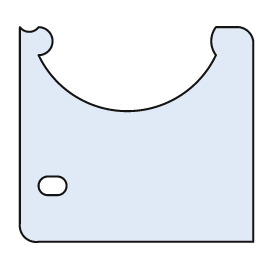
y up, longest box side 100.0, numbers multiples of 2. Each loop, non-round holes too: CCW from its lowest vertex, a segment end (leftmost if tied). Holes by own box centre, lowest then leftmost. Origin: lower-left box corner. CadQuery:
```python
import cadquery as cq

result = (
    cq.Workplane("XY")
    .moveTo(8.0, 0.0)
    .lineTo(100.0, 0.0)
    .lineTo(100.0, 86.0)
    .threePointArc((98.0, 90.0), (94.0, 92.0))
    .lineTo(84.0, 92.0)
    .threePointArc((82.0, 86.0), (84.0, 80.0))
    .threePointArc((46.0, 56.0), (8.0, 80.0))
    .threePointArc((14.0, 86.0), (8.0, 92.0))
    .threePointArc((4.0, 90.0), (0.0, 92.0))
    .lineTo(0.0, 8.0)
    .threePointArc((2.0, 2.0), (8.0, 0.0))
    .close()
    .moveTo(12.0, 20.0)
    .lineTo(16.0, 20.0)
    .threePointArc((20.0, 24.0), (16.0, 28.0))
    .lineTo(12.0, 28.0)
    .threePointArc((8.0, 24.0), (12.0, 20.0))
    .close()
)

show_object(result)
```